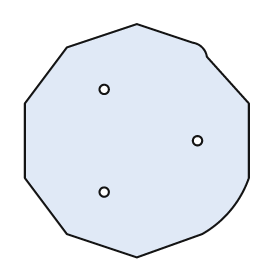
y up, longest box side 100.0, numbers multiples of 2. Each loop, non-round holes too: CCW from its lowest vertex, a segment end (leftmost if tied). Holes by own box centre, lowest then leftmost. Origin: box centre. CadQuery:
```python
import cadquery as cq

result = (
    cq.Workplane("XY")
    .moveTo(0.0, -50.0)
    .lineTo(28.0, -40.0)
    .threePointArc((40.0, -30.0), (48.0, -16.0))
    .lineTo(48.0, 16.0)
    .lineTo(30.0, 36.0)
    .threePointArc((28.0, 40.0), (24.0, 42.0))
    .lineTo(0.0, 50.0)
    .lineTo(-30.0, 40.0)
    .lineTo(-48.0, 16.0)
    .lineTo(-48.0, -16.0)
    .lineTo(-30.0, -40.0)
    .close()
    .moveTo(-14.0, -22.0)
    .circle(2.0)
    .moveTo(26.0, 0.0)
    .circle(2.0)
    .moveTo(-14.0, 22.0)
    .circle(2.0)
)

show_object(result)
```